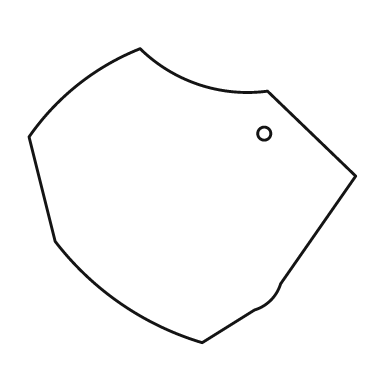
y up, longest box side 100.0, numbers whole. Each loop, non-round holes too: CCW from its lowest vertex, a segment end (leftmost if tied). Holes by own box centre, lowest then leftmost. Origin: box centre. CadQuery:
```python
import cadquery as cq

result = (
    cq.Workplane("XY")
    .moveTo(3.0, -45.0)
    .lineTo(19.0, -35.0)
    .threePointArc((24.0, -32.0), (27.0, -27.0))
    .lineTo(50.0, 6.0)
    .lineTo(23.0, 32.0)
    .threePointArc((2.0, 34.0), (-16.0, 45.0))
    .threePointArc((-35.0, 34.0), (-50.0, 18.0))
    .lineTo(-42.0, -14.0)
    .threePointArc((-22.0, -33.0), (3.0, -45.0))
    .close()
    .moveTo(22.0, 19.0)
    .circle(2.0)
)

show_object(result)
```